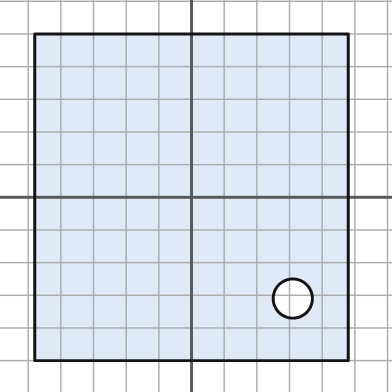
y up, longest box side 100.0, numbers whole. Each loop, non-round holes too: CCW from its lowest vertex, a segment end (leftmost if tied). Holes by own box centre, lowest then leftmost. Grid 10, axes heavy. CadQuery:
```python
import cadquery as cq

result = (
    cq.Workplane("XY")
    .moveTo(-48.0, -50.0)
    .lineTo(48.0, -50.0)
    .lineTo(48.0, 50.0)
    .lineTo(-48.0, 50.0)
    .close()
    .moveTo(31.0, -31.0)
    .circle(6.0)
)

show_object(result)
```